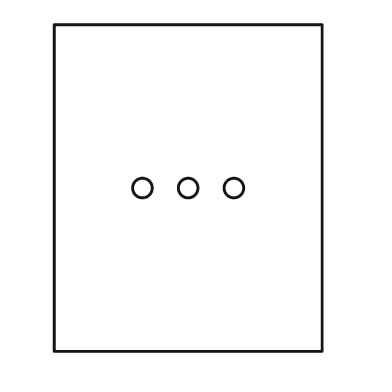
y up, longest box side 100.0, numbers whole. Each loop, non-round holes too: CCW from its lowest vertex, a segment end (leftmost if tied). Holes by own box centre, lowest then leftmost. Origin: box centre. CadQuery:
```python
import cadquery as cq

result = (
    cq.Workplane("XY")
    .moveTo(-41.0, -50.0)
    .lineTo(41.0, -50.0)
    .lineTo(41.0, 50.0)
    .lineTo(-41.0, 50.0)
    .close()
    .moveTo(-14.0, 0.0)
    .circle(3.0)
    .moveTo(0.0, 0.0)
    .circle(3.0)
    .moveTo(14.0, 0.0)
    .circle(3.0)
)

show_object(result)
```